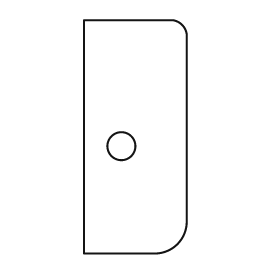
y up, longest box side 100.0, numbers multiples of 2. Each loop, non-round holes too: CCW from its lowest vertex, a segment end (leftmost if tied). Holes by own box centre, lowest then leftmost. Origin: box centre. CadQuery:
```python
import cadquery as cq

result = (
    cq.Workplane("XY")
    .moveTo(-22.0, -50.0)
    .lineTo(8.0, -50.0)
    .threePointArc((18.0, -46.0), (22.0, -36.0))
    .lineTo(22.0, 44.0)
    .threePointArc((20.0, 48.0), (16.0, 50.0))
    .lineTo(-22.0, 50.0)
    .close()
    .moveTo(-6.0, -4.0)
    .circle(6.0)
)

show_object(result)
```